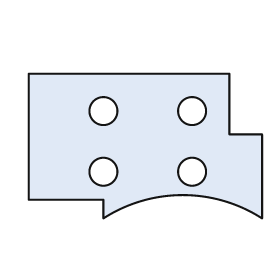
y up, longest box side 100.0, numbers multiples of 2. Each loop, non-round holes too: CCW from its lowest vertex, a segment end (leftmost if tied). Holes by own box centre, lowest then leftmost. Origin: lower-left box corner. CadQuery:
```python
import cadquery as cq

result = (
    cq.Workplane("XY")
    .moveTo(32.0, 0.0)
    .threePointArc((66.0, 10.0), (100.0, 0.0))
    .lineTo(100.0, 36.0)
    .lineTo(86.0, 36.0)
    .lineTo(86.0, 62.0)
    .lineTo(0.0, 62.0)
    .lineTo(0.0, 8.0)
    .lineTo(32.0, 8.0)
    .close()
    .moveTo(32.0, 20.0)
    .circle(6.0)
    .moveTo(70.0, 20.0)
    .circle(6.0)
    .moveTo(32.0, 46.0)
    .circle(6.0)
    .moveTo(70.0, 46.0)
    .circle(6.0)
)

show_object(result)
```